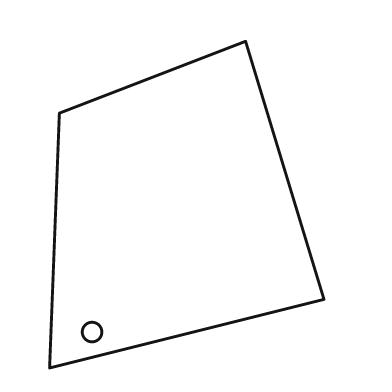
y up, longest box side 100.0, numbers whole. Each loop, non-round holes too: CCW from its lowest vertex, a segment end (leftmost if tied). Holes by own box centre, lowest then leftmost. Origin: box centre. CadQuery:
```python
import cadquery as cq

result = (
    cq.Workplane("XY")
    .moveTo(-42.0, -50.0)
    .lineTo(42.0, -29.0)
    .lineTo(18.0, 50.0)
    .lineTo(-39.0, 28.0)
    .close()
    .moveTo(-29.0, -39.0)
    .circle(3.0)
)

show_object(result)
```